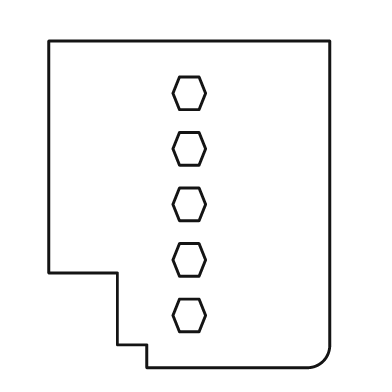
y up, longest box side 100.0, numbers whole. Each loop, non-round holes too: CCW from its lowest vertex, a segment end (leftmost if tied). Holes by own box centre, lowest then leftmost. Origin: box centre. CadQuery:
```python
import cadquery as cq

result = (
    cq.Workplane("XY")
    .moveTo(-13.0, -50.0)
    .lineTo(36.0, -50.0)
    .threePointArc((41.0, -48.0), (43.0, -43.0))
    .lineTo(43.0, 50.0)
    .lineTo(-43.0, 50.0)
    .lineTo(-43.0, -21.0)
    .lineTo(-22.0, -21.0)
    .lineTo(-22.0, -43.0)
    .lineTo(-13.0, -43.0)
    .close()
    .moveTo(-3.0, -39.0)
    .lineTo(3.0, -39.0)
    .lineTo(5.0, -34.0)
    .lineTo(3.0, -29.0)
    .lineTo(-3.0, -29.0)
    .lineTo(-5.0, -34.0)
    .close()
    .moveTo(-3.0, -22.0)
    .lineTo(3.0, -22.0)
    .lineTo(5.0, -17.0)
    .lineTo(3.0, -12.0)
    .lineTo(-3.0, -12.0)
    .lineTo(-5.0, -17.0)
    .close()
    .moveTo(-3.0, -5.0)
    .lineTo(3.0, -5.0)
    .lineTo(5.0, 0.0)
    .lineTo(3.0, 5.0)
    .lineTo(-3.0, 5.0)
    .lineTo(-5.0, 0.0)
    .close()
    .moveTo(-3.0, 12.0)
    .lineTo(3.0, 12.0)
    .lineTo(5.0, 17.0)
    .lineTo(3.0, 22.0)
    .lineTo(-3.0, 22.0)
    .lineTo(-5.0, 17.0)
    .close()
    .moveTo(-3.0, 29.0)
    .lineTo(3.0, 29.0)
    .lineTo(5.0, 34.0)
    .lineTo(3.0, 39.0)
    .lineTo(-3.0, 39.0)
    .lineTo(-5.0, 34.0)
    .close()
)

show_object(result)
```